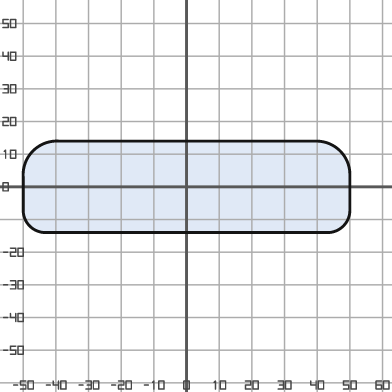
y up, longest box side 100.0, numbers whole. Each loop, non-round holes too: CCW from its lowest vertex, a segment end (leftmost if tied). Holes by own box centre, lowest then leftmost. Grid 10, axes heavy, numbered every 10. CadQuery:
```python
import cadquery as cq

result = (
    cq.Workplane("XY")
    .moveTo(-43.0, -14.0)
    .lineTo(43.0, -14.0)
    .threePointArc((48.0, -12.0), (50.0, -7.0))
    .lineTo(50.0, 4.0)
    .threePointArc((47.0, 11.0), (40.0, 14.0))
    .lineTo(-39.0, 14.0)
    .threePointArc((-47.0, 11.0), (-50.0, 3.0))
    .lineTo(-50.0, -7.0)
    .threePointArc((-48.0, -12.0), (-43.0, -14.0))
    .close()
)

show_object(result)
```